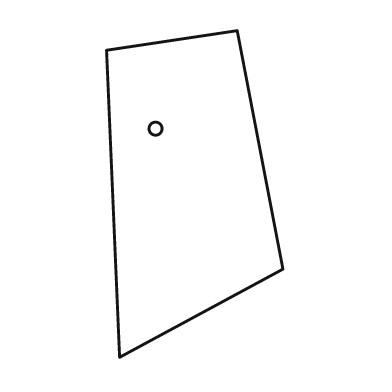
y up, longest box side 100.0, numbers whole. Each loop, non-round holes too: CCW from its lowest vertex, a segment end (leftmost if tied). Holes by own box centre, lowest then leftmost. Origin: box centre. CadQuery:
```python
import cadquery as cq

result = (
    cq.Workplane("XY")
    .moveTo(-23.0, -50.0)
    .lineTo(27.0, -23.0)
    .lineTo(13.0, 50.0)
    .lineTo(-27.0, 44.0)
    .close()
    .moveTo(-12.0, 20.0)
    .circle(2.0)
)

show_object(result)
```